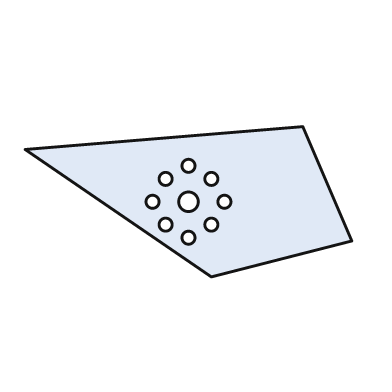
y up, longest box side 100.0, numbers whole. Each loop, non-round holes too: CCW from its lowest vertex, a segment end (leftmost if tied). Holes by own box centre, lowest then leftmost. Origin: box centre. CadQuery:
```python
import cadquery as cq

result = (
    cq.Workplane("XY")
    .moveTo(7.0, -23.0)
    .lineTo(50.0, -12.0)
    .lineTo(35.0, 23.0)
    .lineTo(-50.0, 16.0)
    .close()
    .moveTo(0.0, -11.0)
    .circle(2.0)
    .moveTo(-7.0, -7.0)
    .circle(2.0)
    .moveTo(7.0, -7.0)
    .circle(2.0)
    .moveTo(-11.0, 0.0)
    .circle(2.0)
    .moveTo(0.0, 0.0)
    .circle(3.0)
    .moveTo(11.0, 0.0)
    .circle(2.0)
    .moveTo(-7.0, 7.0)
    .circle(2.0)
    .moveTo(7.0, 7.0)
    .circle(2.0)
    .moveTo(0.0, 11.0)
    .circle(2.0)
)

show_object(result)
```